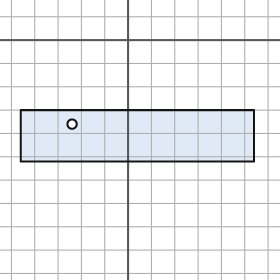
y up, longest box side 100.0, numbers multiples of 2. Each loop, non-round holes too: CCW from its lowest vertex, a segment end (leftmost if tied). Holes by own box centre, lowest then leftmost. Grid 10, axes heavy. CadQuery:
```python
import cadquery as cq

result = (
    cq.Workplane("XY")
    .moveTo(-46.0, -52.0)
    .lineTo(54.0, -52.0)
    .lineTo(54.0, -30.0)
    .lineTo(-46.0, -30.0)
    .close()
    .moveTo(-24.0, -36.0)
    .circle(2.0)
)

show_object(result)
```